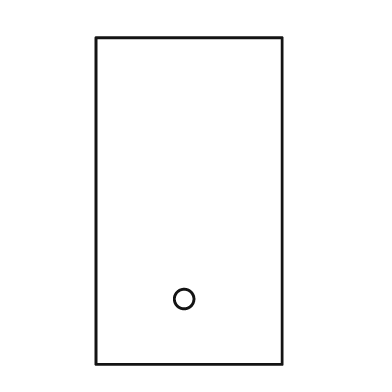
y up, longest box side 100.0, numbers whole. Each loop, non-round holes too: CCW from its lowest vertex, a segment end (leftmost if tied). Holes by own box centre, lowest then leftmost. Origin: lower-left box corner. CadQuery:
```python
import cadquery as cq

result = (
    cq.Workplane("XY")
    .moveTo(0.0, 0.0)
    .lineTo(57.0, 0.0)
    .lineTo(57.0, 100.0)
    .lineTo(0.0, 100.0)
    .close()
    .moveTo(27.0, 20.0)
    .circle(3.0)
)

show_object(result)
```